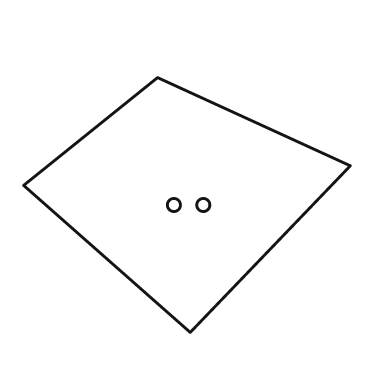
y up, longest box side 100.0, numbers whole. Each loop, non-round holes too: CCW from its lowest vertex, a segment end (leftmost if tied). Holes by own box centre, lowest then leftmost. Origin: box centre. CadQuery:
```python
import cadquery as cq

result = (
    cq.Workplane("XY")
    .moveTo(1.0, -39.0)
    .lineTo(50.0, 12.0)
    .lineTo(-9.0, 39.0)
    .lineTo(-50.0, 6.0)
    .close()
    .moveTo(-4.0, 0.0)
    .circle(2.0)
    .moveTo(5.0, 0.0)
    .circle(2.0)
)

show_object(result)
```